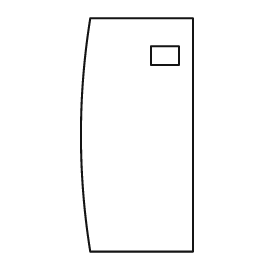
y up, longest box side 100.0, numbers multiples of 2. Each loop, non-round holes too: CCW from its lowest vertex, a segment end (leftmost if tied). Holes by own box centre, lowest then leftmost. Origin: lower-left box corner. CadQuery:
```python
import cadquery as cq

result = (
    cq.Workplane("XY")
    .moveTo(4.0, 0.0)
    .lineTo(48.0, 0.0)
    .lineTo(48.0, 100.0)
    .lineTo(4.0, 100.0)
    .threePointArc((0.0, 50.0), (4.0, 0.0))
    .close()
    .moveTo(30.0, 80.0)
    .lineTo(42.0, 80.0)
    .lineTo(42.0, 88.0)
    .lineTo(30.0, 88.0)
    .close()
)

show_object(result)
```